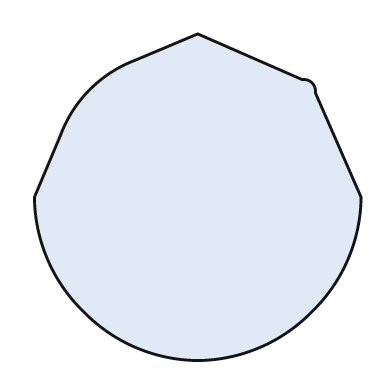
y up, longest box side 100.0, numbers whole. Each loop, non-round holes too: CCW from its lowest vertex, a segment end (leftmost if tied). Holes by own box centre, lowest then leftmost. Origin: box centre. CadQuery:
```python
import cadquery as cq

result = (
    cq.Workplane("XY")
    .moveTo(0.0, -50.0)
    .threePointArc((19.0, -46.0), (35.0, -35.0))
    .threePointArc((46.0, -19.0), (50.0, 0.0))
    .lineTo(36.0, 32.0)
    .threePointArc((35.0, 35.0), (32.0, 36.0))
    .lineTo(0.0, 50.0)
    .lineTo(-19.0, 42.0)
    .threePointArc((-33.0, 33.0), (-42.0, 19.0))
    .lineTo(-50.0, 0.0)
    .threePointArc((-46.0, -19.0), (-35.0, -35.0))
    .threePointArc((-19.0, -46.0), (0.0, -50.0))
    .close()
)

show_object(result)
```